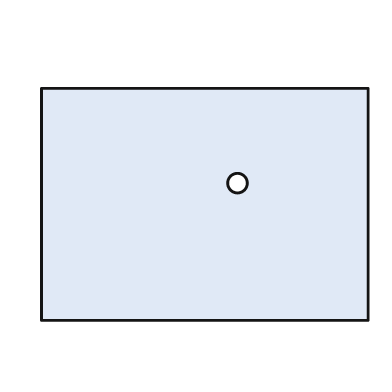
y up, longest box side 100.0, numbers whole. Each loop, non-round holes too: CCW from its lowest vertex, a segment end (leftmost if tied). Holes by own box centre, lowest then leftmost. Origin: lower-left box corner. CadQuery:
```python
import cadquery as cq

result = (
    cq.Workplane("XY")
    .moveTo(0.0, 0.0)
    .lineTo(100.0, 0.0)
    .lineTo(100.0, 71.0)
    .lineTo(0.0, 71.0)
    .close()
    .moveTo(60.0, 42.0)
    .circle(3.0)
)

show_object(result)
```